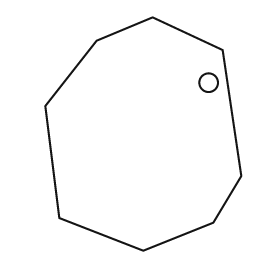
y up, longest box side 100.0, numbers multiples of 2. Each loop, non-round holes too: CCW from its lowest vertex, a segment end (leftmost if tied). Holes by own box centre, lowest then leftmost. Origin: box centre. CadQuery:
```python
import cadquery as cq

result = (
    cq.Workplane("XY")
    .moveTo(0.0, -50.0)
    .lineTo(30.0, -38.0)
    .lineTo(42.0, -18.0)
    .lineTo(34.0, 36.0)
    .lineTo(4.0, 50.0)
    .lineTo(-20.0, 40.0)
    .lineTo(-42.0, 12.0)
    .lineTo(-36.0, -36.0)
    .close()
    .moveTo(28.0, 22.0)
    .circle(4.0)
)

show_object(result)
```